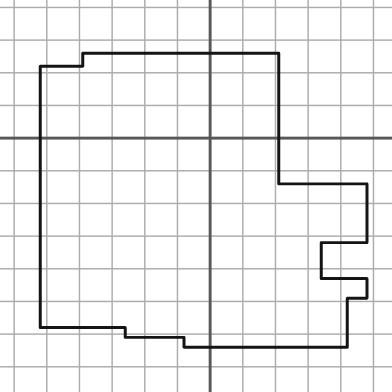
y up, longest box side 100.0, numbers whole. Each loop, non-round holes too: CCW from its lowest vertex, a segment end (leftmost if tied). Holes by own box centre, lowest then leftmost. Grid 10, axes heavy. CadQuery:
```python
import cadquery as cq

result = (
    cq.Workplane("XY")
    .moveTo(-8.0, -64.0)
    .lineTo(42.0, -64.0)
    .lineTo(42.0, -49.0)
    .lineTo(48.0, -49.0)
    .lineTo(48.0, -43.0)
    .lineTo(34.0, -43.0)
    .lineTo(34.0, -32.0)
    .lineTo(48.0, -32.0)
    .lineTo(48.0, -14.0)
    .lineTo(21.0, -14.0)
    .lineTo(21.0, 26.0)
    .lineTo(-39.0, 26.0)
    .lineTo(-39.0, 22.0)
    .lineTo(-52.0, 22.0)
    .lineTo(-52.0, -58.0)
    .lineTo(-26.0, -58.0)
    .lineTo(-26.0, -61.0)
    .lineTo(-8.0, -61.0)
    .close()
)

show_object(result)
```